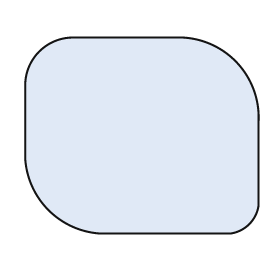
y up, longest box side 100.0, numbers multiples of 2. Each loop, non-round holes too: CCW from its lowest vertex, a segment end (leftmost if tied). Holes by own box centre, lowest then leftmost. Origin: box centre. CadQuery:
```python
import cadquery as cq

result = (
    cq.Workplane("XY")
    .moveTo(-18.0, -42.0)
    .lineTo(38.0, -42.0)
    .threePointArc((46.0, -38.0), (50.0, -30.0))
    .lineTo(50.0, 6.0)
    .threePointArc((40.0, 32.0), (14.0, 42.0))
    .lineTo(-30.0, 42.0)
    .threePointArc((-44.0, 36.0), (-50.0, 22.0))
    .lineTo(-50.0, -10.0)
    .threePointArc((-40.0, -32.0), (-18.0, -42.0))
    .close()
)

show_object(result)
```